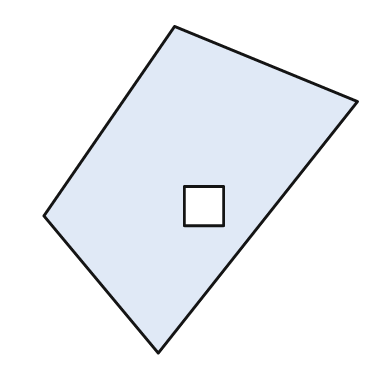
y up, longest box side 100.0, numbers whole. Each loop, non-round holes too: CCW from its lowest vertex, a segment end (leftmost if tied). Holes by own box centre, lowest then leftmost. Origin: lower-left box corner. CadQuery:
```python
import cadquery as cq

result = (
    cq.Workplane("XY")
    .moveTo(35.0, 0.0)
    .lineTo(96.0, 77.0)
    .lineTo(40.0, 100.0)
    .lineTo(0.0, 42.0)
    .close()
    .moveTo(43.0, 39.0)
    .lineTo(55.0, 39.0)
    .lineTo(55.0, 51.0)
    .lineTo(43.0, 51.0)
    .close()
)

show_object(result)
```